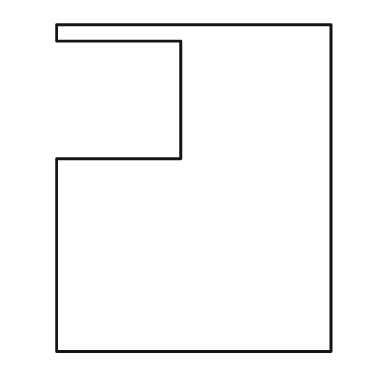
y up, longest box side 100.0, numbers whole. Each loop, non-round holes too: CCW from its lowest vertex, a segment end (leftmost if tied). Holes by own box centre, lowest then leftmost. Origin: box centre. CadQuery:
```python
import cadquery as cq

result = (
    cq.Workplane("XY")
    .moveTo(-42.0, -50.0)
    .lineTo(42.0, -50.0)
    .lineTo(42.0, 50.0)
    .lineTo(-42.0, 50.0)
    .lineTo(-42.0, 45.0)
    .lineTo(-4.0, 45.0)
    .lineTo(-4.0, 9.0)
    .lineTo(-42.0, 9.0)
    .close()
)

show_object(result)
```